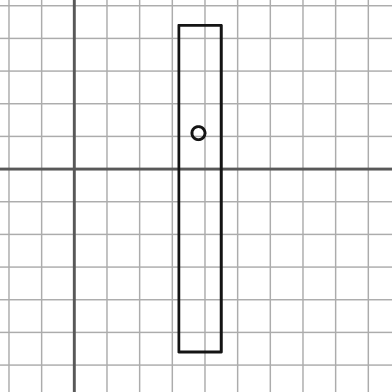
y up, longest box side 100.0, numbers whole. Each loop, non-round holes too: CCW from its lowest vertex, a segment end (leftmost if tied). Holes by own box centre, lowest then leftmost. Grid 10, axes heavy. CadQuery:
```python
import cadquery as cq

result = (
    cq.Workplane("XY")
    .moveTo(32.0, -56.0)
    .lineTo(45.0, -56.0)
    .lineTo(45.0, 44.0)
    .lineTo(32.0, 44.0)
    .close()
    .moveTo(38.0, 11.0)
    .circle(2.0)
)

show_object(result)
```